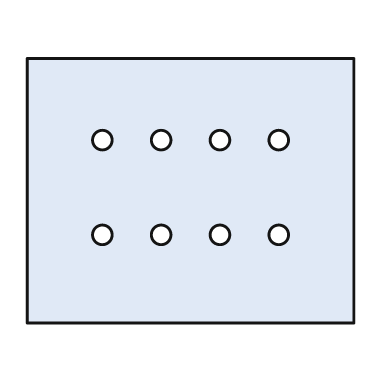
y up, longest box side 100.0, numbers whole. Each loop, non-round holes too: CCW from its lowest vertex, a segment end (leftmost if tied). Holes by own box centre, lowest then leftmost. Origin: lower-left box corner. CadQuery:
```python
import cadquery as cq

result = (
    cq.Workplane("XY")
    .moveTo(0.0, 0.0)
    .lineTo(100.0, 0.0)
    .lineTo(100.0, 81.0)
    .lineTo(0.0, 81.0)
    .close()
    .moveTo(23.0, 27.0)
    .circle(3.0)
    .moveTo(41.0, 27.0)
    .circle(3.0)
    .moveTo(59.0, 27.0)
    .circle(3.0)
    .moveTo(77.0, 27.0)
    .circle(3.0)
    .moveTo(23.0, 56.0)
    .circle(3.0)
    .moveTo(41.0, 56.0)
    .circle(3.0)
    .moveTo(59.0, 56.0)
    .circle(3.0)
    .moveTo(77.0, 56.0)
    .circle(3.0)
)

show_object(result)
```